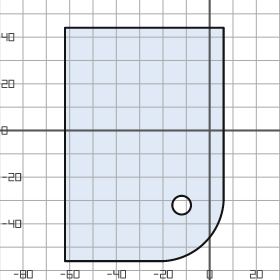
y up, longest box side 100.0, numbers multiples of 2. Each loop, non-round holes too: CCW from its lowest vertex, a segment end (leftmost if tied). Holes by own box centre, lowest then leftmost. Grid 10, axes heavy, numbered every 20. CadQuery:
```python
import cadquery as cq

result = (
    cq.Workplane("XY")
    .moveTo(-62.0, -56.0)
    .lineTo(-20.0, -56.0)
    .threePointArc((-2.0, -48.0), (6.0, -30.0))
    .lineTo(6.0, 44.0)
    .lineTo(-62.0, 44.0)
    .close()
    .moveTo(-12.0, -32.0)
    .circle(4.0)
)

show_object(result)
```